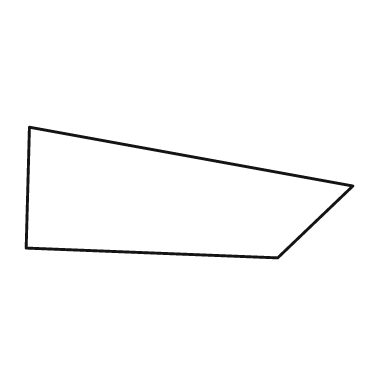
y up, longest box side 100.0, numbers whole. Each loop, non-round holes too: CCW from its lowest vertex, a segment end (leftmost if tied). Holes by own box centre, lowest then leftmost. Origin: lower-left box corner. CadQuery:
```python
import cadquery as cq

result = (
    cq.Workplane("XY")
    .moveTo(77.0, 0.0)
    .lineTo(100.0, 22.0)
    .lineTo(1.0, 40.0)
    .lineTo(0.0, 3.0)
    .close()
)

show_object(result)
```